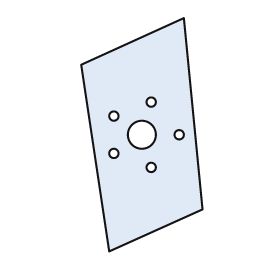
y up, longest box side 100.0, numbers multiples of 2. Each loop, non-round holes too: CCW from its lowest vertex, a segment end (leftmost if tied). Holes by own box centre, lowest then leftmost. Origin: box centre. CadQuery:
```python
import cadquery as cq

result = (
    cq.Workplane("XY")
    .moveTo(-14.0, -50.0)
    .lineTo(26.0, -32.0)
    .lineTo(18.0, 50.0)
    .lineTo(-26.0, 30.0)
    .close()
    .moveTo(4.0, -14.0)
    .circle(2.0)
    .moveTo(-12.0, -8.0)
    .circle(2.0)
    .moveTo(0.0, 0.0)
    .circle(6.0)
    .moveTo(16.0, 0.0)
    .circle(2.0)
    .moveTo(-12.0, 8.0)
    .circle(2.0)
    .moveTo(4.0, 14.0)
    .circle(2.0)
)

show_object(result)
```